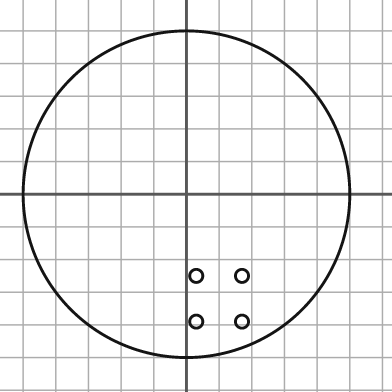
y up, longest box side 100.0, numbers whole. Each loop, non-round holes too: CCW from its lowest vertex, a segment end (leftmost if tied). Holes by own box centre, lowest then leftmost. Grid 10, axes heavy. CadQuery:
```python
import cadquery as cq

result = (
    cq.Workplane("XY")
    .moveTo(0.0, 0.0)
    .circle(50.0)
    .moveTo(3.0, -39.0)
    .circle(2.0)
    .moveTo(17.0, -39.0)
    .circle(2.0)
    .moveTo(3.0, -25.0)
    .circle(2.0)
    .moveTo(17.0, -25.0)
    .circle(2.0)
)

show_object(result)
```